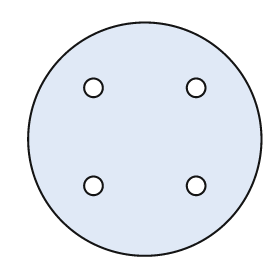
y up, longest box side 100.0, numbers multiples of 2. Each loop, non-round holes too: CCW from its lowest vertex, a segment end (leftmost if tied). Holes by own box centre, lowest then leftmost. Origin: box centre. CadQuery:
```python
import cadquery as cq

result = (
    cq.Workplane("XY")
    .moveTo(0.0, 0.0)
    .circle(50.0)
    .moveTo(-22.0, -20.0)
    .circle(4.0)
    .moveTo(22.0, -20.0)
    .circle(4.0)
    .moveTo(-22.0, 22.0)
    .circle(4.0)
    .moveTo(22.0, 22.0)
    .circle(4.0)
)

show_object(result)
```